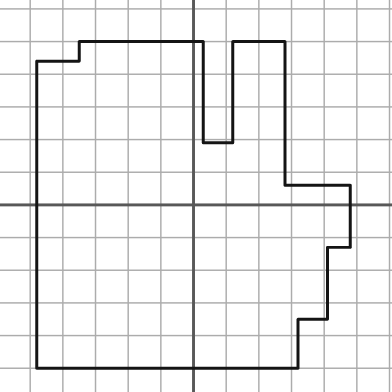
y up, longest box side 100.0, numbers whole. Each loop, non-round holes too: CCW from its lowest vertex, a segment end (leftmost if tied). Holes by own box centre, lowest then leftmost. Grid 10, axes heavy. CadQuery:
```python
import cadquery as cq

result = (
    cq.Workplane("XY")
    .moveTo(-48.0, -50.0)
    .lineTo(32.0, -50.0)
    .lineTo(32.0, -35.0)
    .lineTo(41.0, -35.0)
    .lineTo(41.0, -13.0)
    .lineTo(48.0, -13.0)
    .lineTo(48.0, 6.0)
    .lineTo(28.0, 6.0)
    .lineTo(28.0, 50.0)
    .lineTo(12.0, 50.0)
    .lineTo(12.0, 19.0)
    .lineTo(3.0, 19.0)
    .lineTo(3.0, 50.0)
    .lineTo(-35.0, 50.0)
    .lineTo(-35.0, 44.0)
    .lineTo(-48.0, 44.0)
    .close()
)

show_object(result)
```